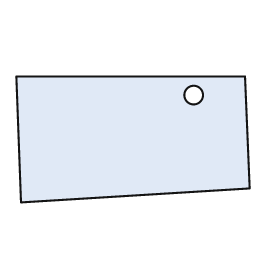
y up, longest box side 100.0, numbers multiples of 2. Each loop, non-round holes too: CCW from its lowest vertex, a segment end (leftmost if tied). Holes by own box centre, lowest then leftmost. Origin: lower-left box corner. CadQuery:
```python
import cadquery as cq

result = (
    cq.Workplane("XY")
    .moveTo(2.0, 0.0)
    .lineTo(100.0, 6.0)
    .lineTo(98.0, 54.0)
    .lineTo(0.0, 54.0)
    .close()
    .moveTo(76.0, 46.0)
    .circle(4.0)
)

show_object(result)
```